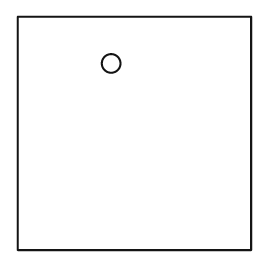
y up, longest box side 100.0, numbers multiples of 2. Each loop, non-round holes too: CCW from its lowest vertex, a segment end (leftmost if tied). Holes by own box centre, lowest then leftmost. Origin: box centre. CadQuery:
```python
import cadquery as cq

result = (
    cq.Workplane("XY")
    .moveTo(-50.0, -50.0)
    .lineTo(50.0, -50.0)
    .lineTo(50.0, 50.0)
    .lineTo(-50.0, 50.0)
    .close()
    .moveTo(-10.0, 30.0)
    .circle(4.0)
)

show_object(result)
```